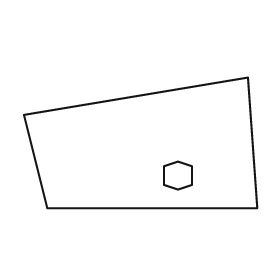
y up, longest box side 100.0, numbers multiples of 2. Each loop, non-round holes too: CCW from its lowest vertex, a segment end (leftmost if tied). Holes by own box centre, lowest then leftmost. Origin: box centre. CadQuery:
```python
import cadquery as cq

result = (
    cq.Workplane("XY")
    .moveTo(-40.0, -28.0)
    .lineTo(50.0, -28.0)
    .lineTo(46.0, 28.0)
    .lineTo(-50.0, 12.0)
    .close()
    .moveTo(16.0, -20.0)
    .lineTo(22.0, -18.0)
    .lineTo(22.0, -10.0)
    .lineTo(16.0, -8.0)
    .lineTo(10.0, -10.0)
    .lineTo(10.0, -18.0)
    .close()
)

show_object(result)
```